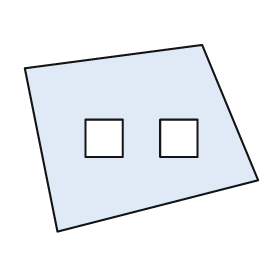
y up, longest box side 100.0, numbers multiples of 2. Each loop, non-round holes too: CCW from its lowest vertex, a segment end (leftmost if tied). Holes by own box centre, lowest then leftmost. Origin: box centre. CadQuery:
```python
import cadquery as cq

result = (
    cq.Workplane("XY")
    .moveTo(-36.0, -40.0)
    .lineTo(50.0, -18.0)
    .lineTo(26.0, 40.0)
    .lineTo(-50.0, 30.0)
    .close()
    .moveTo(-24.0, -8.0)
    .lineTo(-8.0, -8.0)
    .lineTo(-8.0, 8.0)
    .lineTo(-24.0, 8.0)
    .close()
    .moveTo(8.0, -8.0)
    .lineTo(24.0, -8.0)
    .lineTo(24.0, 8.0)
    .lineTo(8.0, 8.0)
    .close()
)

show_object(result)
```